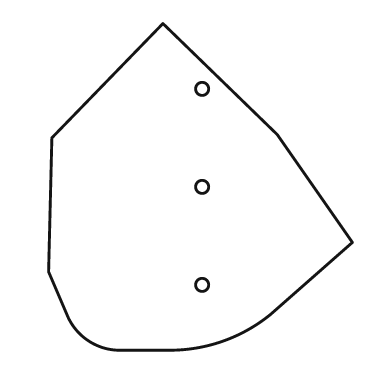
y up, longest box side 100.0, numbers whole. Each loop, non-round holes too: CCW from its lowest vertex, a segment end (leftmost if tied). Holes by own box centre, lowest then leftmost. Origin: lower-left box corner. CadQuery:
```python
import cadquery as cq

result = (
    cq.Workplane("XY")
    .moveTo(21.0, 0.0)
    .lineTo(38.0, 0.0)
    .threePointArc((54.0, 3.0), (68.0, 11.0))
    .lineTo(93.0, 33.0)
    .lineTo(70.0, 66.0)
    .lineTo(35.0, 100.0)
    .lineTo(1.0, 65.0)
    .lineTo(0.0, 24.0)
    .lineTo(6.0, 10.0)
    .threePointArc((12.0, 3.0), (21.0, 0.0))
    .close()
    .moveTo(47.0, 20.0)
    .circle(2.0)
    .moveTo(47.0, 50.0)
    .circle(2.0)
    .moveTo(47.0, 80.0)
    .circle(2.0)
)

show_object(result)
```